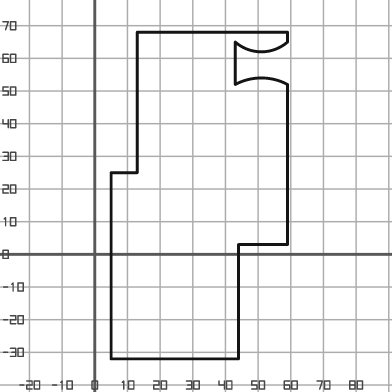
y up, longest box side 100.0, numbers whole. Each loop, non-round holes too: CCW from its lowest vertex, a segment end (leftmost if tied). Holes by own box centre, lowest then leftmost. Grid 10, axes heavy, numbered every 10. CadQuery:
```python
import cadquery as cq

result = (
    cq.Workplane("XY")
    .moveTo(5.0, -32.0)
    .lineTo(44.0, -32.0)
    .lineTo(44.0, 3.0)
    .lineTo(59.0, 3.0)
    .lineTo(59.0, 52.0)
    .threePointArc((51.0, 54.0), (43.0, 52.0))
    .lineTo(43.0, 65.0)
    .threePointArc((51.0, 62.0), (59.0, 65.0))
    .lineTo(59.0, 68.0)
    .lineTo(13.0, 68.0)
    .lineTo(13.0, 25.0)
    .lineTo(5.0, 25.0)
    .close()
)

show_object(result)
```